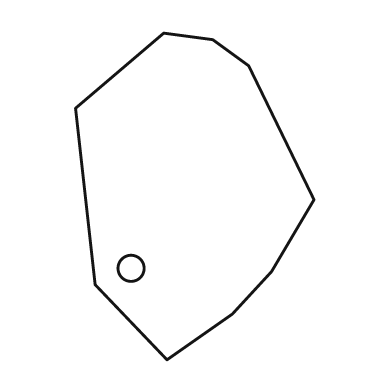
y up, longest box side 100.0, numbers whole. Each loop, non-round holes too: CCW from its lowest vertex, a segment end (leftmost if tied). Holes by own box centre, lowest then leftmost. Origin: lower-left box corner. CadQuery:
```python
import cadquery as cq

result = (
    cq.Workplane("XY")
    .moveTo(28.0, 0.0)
    .lineTo(48.0, 14.0)
    .lineTo(60.0, 27.0)
    .lineTo(73.0, 49.0)
    .lineTo(53.0, 90.0)
    .lineTo(42.0, 98.0)
    .lineTo(27.0, 100.0)
    .lineTo(0.0, 77.0)
    .lineTo(6.0, 23.0)
    .close()
    .moveTo(17.0, 28.0)
    .circle(4.0)
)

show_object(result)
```